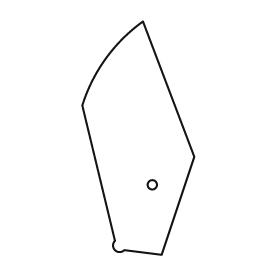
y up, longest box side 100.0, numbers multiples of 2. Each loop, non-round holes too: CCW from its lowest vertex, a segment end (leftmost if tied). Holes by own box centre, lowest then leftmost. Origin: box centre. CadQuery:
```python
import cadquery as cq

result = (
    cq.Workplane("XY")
    .moveTo(10.0, -50.0)
    .lineTo(24.0, -8.0)
    .lineTo(2.0, 50.0)
    .threePointArc((-14.0, 34.0), (-24.0, 14.0))
    .lineTo(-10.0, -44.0)
    .threePointArc((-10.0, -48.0), (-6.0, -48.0))
    .close()
    .moveTo(6.0, -20.0)
    .circle(2.0)
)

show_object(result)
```